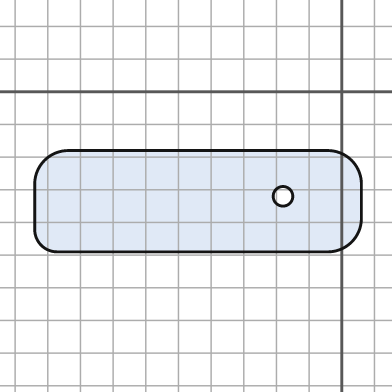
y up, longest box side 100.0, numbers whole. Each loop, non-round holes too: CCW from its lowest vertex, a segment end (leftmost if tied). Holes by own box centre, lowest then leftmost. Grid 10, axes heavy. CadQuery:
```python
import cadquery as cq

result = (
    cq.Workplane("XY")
    .moveTo(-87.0, -49.0)
    .lineTo(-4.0, -49.0)
    .threePointArc((3.0, -46.0), (6.0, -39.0))
    .lineTo(6.0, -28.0)
    .threePointArc((3.0, -21.0), (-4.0, -18.0))
    .lineTo(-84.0, -18.0)
    .threePointArc((-91.0, -21.0), (-94.0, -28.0))
    .lineTo(-94.0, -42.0)
    .threePointArc((-92.0, -47.0), (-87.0, -49.0))
    .close()
    .moveTo(-18.0, -32.0)
    .circle(3.0)
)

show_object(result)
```